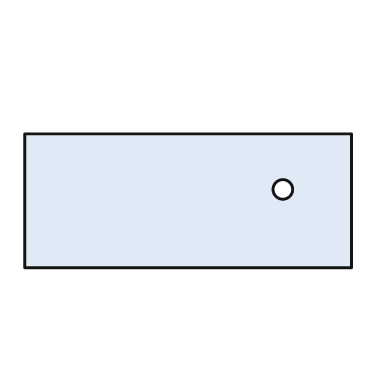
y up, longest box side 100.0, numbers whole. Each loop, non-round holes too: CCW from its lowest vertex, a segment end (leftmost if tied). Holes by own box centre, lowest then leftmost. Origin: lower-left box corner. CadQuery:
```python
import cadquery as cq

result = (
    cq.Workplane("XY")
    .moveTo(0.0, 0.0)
    .lineTo(100.0, 0.0)
    .lineTo(100.0, 41.0)
    .lineTo(0.0, 41.0)
    .close()
    .moveTo(79.0, 24.0)
    .circle(3.0)
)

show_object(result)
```